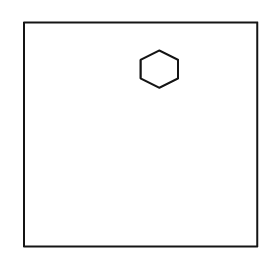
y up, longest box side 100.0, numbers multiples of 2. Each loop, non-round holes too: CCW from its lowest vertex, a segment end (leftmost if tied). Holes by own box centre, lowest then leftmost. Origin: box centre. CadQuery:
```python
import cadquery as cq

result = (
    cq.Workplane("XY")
    .moveTo(-50.0, -48.0)
    .lineTo(50.0, -48.0)
    .lineTo(50.0, 48.0)
    .lineTo(-50.0, 48.0)
    .close()
    .moveTo(8.0, 20.0)
    .lineTo(16.0, 24.0)
    .lineTo(16.0, 32.0)
    .lineTo(8.0, 36.0)
    .lineTo(0.0, 32.0)
    .lineTo(0.0, 24.0)
    .close()
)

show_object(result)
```